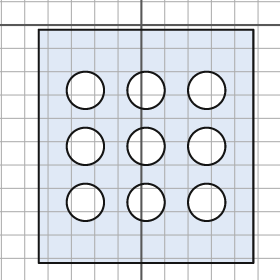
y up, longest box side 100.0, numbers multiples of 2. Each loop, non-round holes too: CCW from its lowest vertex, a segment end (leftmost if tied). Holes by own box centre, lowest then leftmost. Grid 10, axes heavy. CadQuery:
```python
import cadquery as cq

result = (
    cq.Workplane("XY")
    .moveTo(-44.0, -102.0)
    .lineTo(48.0, -102.0)
    .lineTo(48.0, -2.0)
    .lineTo(-44.0, -2.0)
    .close()
    .moveTo(-24.0, -76.0)
    .circle(8.0)
    .moveTo(2.0, -76.0)
    .circle(8.0)
    .moveTo(28.0, -76.0)
    .circle(8.0)
    .moveTo(-24.0, -52.0)
    .circle(8.0)
    .moveTo(2.0, -52.0)
    .circle(8.0)
    .moveTo(28.0, -52.0)
    .circle(8.0)
    .moveTo(-24.0, -28.0)
    .circle(8.0)
    .moveTo(2.0, -28.0)
    .circle(8.0)
    .moveTo(28.0, -28.0)
    .circle(8.0)
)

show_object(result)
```